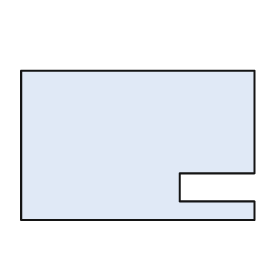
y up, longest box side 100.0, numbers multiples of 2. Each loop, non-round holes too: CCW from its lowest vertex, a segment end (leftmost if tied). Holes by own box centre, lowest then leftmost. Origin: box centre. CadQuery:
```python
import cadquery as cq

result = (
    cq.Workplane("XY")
    .moveTo(-50.0, -32.0)
    .lineTo(50.0, -32.0)
    .lineTo(50.0, -24.0)
    .lineTo(18.0, -24.0)
    .lineTo(18.0, -12.0)
    .lineTo(50.0, -12.0)
    .lineTo(50.0, 32.0)
    .lineTo(-50.0, 32.0)
    .close()
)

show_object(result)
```